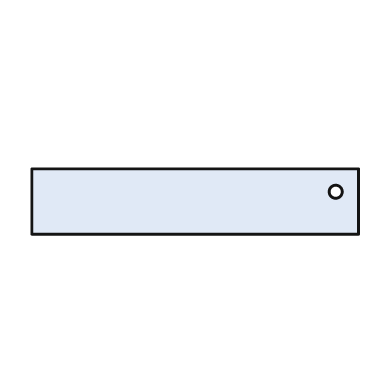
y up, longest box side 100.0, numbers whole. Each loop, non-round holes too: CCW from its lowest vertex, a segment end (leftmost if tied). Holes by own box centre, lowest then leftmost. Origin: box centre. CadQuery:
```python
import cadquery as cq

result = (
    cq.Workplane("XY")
    .moveTo(-50.0, -10.0)
    .lineTo(50.0, -10.0)
    .lineTo(50.0, 10.0)
    .lineTo(-50.0, 10.0)
    .close()
    .moveTo(43.0, 3.0)
    .circle(2.0)
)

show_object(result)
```